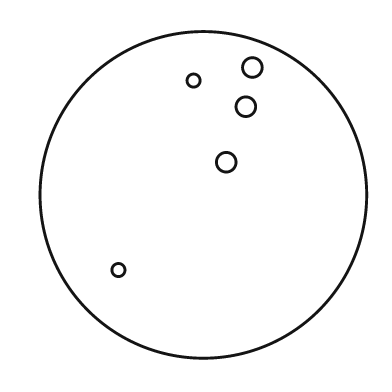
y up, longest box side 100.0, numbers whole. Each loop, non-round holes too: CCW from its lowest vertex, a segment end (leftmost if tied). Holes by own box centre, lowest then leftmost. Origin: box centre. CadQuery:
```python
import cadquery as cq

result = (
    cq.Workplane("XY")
    .moveTo(0.0, 0.0)
    .circle(50.0)
    .moveTo(-26.0, -23.0)
    .circle(2.0)
    .moveTo(7.0, 10.0)
    .circle(3.0)
    .moveTo(13.0, 27.0)
    .circle(3.0)
    .moveTo(-3.0, 35.0)
    .circle(2.0)
    .moveTo(15.0, 39.0)
    .circle(3.0)
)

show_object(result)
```